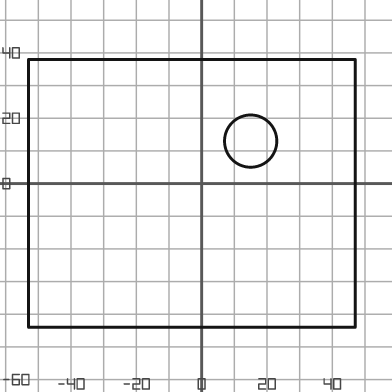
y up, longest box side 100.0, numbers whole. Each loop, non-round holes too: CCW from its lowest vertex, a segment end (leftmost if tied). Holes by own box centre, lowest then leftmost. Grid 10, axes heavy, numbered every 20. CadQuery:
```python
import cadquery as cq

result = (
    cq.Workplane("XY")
    .moveTo(-53.0, -44.0)
    .lineTo(47.0, -44.0)
    .lineTo(47.0, 38.0)
    .lineTo(-53.0, 38.0)
    .close()
    .moveTo(15.0, 13.0)
    .circle(8.0)
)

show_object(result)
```